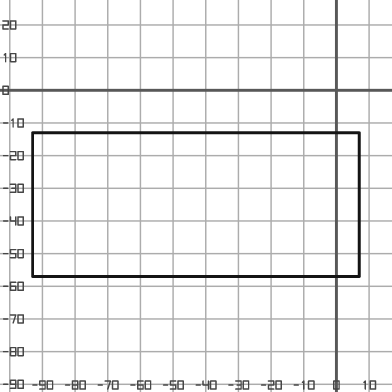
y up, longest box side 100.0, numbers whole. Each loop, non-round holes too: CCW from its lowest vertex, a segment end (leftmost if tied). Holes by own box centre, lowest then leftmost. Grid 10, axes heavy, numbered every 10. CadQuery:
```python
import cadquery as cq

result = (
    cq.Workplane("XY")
    .moveTo(-93.0, -57.0)
    .lineTo(7.0, -57.0)
    .lineTo(7.0, -13.0)
    .lineTo(-93.0, -13.0)
    .close()
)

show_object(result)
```